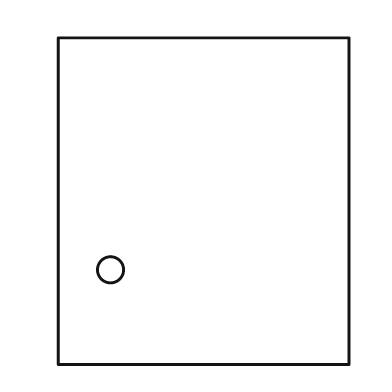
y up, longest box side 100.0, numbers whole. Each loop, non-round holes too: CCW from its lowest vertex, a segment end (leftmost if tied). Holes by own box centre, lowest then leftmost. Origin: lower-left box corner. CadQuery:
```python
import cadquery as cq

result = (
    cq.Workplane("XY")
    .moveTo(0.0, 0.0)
    .lineTo(89.0, 0.0)
    .lineTo(89.0, 100.0)
    .lineTo(0.0, 100.0)
    .close()
    .moveTo(16.0, 29.0)
    .circle(4.0)
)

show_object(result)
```